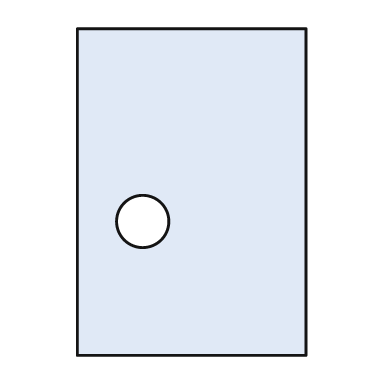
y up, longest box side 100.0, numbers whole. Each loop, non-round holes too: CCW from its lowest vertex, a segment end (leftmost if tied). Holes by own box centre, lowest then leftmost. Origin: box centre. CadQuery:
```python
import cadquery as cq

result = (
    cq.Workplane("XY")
    .moveTo(-35.0, -50.0)
    .lineTo(35.0, -50.0)
    .lineTo(35.0, 50.0)
    .lineTo(-35.0, 50.0)
    .close()
    .moveTo(-15.0, -9.0)
    .circle(8.0)
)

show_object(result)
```